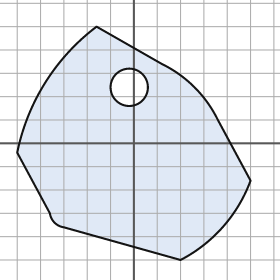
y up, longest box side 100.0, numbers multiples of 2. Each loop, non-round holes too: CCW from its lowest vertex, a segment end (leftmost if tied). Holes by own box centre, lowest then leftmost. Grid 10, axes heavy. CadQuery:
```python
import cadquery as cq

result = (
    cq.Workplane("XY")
    .moveTo(20.0, -50.0)
    .threePointArc((38.0, -36.0), (50.0, -16.0))
    .lineTo(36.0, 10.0)
    .threePointArc((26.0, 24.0), (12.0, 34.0))
    .lineTo(-16.0, 50.0)
    .threePointArc((-38.0, 26.0), (-50.0, -4.0))
    .lineTo(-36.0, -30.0)
    .threePointArc((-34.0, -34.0), (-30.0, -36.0))
    .close()
    .moveTo(-2.0, 24.0)
    .circle(8.0)
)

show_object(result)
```